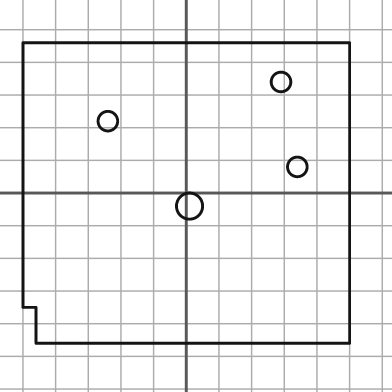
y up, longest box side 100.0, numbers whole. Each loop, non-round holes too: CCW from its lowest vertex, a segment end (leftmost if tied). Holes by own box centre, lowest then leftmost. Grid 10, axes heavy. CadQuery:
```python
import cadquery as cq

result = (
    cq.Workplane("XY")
    .moveTo(-46.0, -46.0)
    .lineTo(50.0, -46.0)
    .lineTo(50.0, 46.0)
    .lineTo(-50.0, 46.0)
    .lineTo(-50.0, -35.0)
    .lineTo(-46.0, -35.0)
    .close()
    .moveTo(1.0, -4.0)
    .circle(4.0)
    .moveTo(34.0, 8.0)
    .circle(3.0)
    .moveTo(-24.0, 22.0)
    .circle(3.0)
    .moveTo(29.0, 34.0)
    .circle(3.0)
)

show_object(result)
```